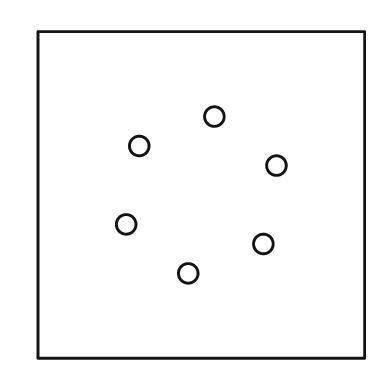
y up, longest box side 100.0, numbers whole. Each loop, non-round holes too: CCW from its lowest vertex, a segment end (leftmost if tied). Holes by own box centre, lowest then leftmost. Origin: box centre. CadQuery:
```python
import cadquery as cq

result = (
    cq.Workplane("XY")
    .moveTo(-50.0, -50.0)
    .lineTo(50.0, -50.0)
    .lineTo(50.0, 50.0)
    .lineTo(-50.0, 50.0)
    .close()
    .moveTo(-4.0, -24.0)
    .circle(3.0)
    .moveTo(19.0, -15.0)
    .circle(3.0)
    .moveTo(-23.0, -9.0)
    .circle(3.0)
    .moveTo(23.0, 9.0)
    .circle(3.0)
    .moveTo(-19.0, 15.0)
    .circle(3.0)
    .moveTo(4.0, 24.0)
    .circle(3.0)
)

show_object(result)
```